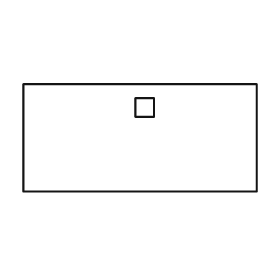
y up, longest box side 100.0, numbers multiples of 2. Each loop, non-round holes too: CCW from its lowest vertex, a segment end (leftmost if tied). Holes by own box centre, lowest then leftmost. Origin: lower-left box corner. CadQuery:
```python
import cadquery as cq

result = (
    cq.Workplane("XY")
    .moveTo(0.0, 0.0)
    .lineTo(100.0, 0.0)
    .lineTo(100.0, 46.0)
    .lineTo(0.0, 46.0)
    .close()
    .moveTo(48.0, 32.0)
    .lineTo(56.0, 32.0)
    .lineTo(56.0, 40.0)
    .lineTo(48.0, 40.0)
    .close()
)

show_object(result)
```